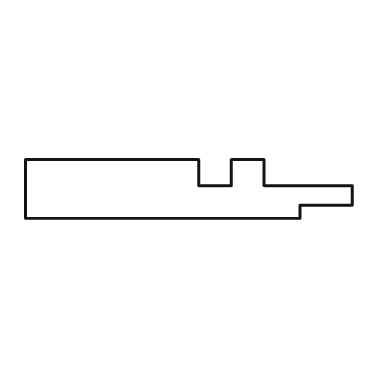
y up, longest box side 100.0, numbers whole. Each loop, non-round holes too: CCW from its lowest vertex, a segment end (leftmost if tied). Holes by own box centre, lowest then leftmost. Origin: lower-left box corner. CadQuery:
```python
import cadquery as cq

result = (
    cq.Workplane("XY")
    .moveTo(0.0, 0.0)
    .lineTo(84.0, 0.0)
    .lineTo(84.0, 4.0)
    .lineTo(100.0, 4.0)
    .lineTo(100.0, 10.0)
    .lineTo(73.0, 10.0)
    .lineTo(73.0, 18.0)
    .lineTo(63.0, 18.0)
    .lineTo(63.0, 10.0)
    .lineTo(53.0, 10.0)
    .lineTo(53.0, 18.0)
    .lineTo(0.0, 18.0)
    .close()
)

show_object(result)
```